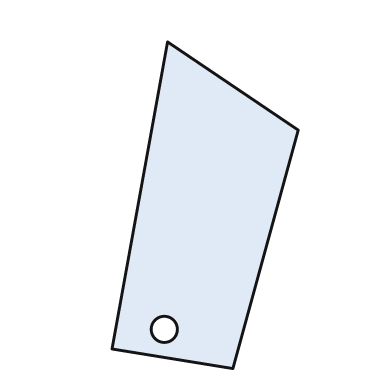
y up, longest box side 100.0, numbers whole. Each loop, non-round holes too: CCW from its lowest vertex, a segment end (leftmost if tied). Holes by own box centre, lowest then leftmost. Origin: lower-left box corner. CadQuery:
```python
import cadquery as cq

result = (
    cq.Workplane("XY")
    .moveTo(37.0, 0.0)
    .lineTo(57.0, 73.0)
    .lineTo(17.0, 100.0)
    .lineTo(0.0, 6.0)
    .close()
    .moveTo(16.0, 12.0)
    .circle(4.0)
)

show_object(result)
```